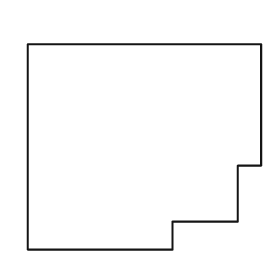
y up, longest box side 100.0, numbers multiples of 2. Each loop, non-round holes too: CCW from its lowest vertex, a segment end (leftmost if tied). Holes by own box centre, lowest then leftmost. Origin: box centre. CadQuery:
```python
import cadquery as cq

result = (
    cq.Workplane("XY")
    .moveTo(-50.0, -44.0)
    .lineTo(12.0, -44.0)
    .lineTo(12.0, -32.0)
    .lineTo(40.0, -32.0)
    .lineTo(40.0, -8.0)
    .lineTo(50.0, -8.0)
    .lineTo(50.0, 44.0)
    .lineTo(-50.0, 44.0)
    .close()
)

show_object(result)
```